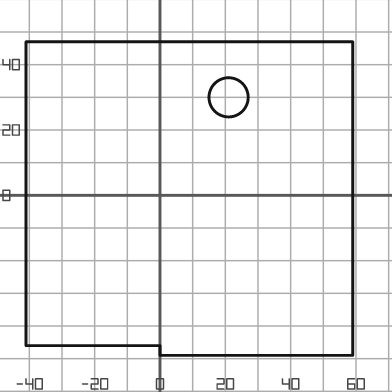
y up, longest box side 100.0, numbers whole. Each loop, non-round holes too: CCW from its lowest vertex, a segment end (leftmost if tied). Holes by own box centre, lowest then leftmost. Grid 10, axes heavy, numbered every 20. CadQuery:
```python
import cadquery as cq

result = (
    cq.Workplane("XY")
    .moveTo(0.0, -49.0)
    .lineTo(59.0, -49.0)
    .lineTo(59.0, 47.0)
    .lineTo(-41.0, 47.0)
    .lineTo(-41.0, -46.0)
    .lineTo(0.0, -46.0)
    .close()
    .moveTo(21.0, 30.0)
    .circle(6.0)
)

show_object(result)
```